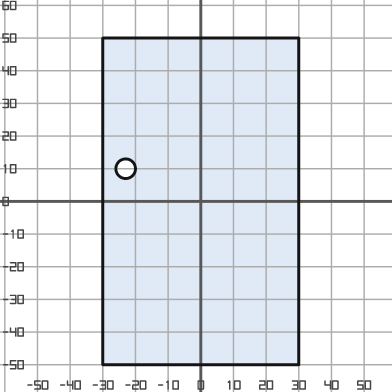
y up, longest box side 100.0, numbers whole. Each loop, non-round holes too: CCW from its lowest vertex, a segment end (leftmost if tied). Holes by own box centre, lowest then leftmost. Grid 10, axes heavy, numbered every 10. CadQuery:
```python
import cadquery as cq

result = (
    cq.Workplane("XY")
    .moveTo(-30.0, -50.0)
    .lineTo(30.0, -50.0)
    .lineTo(30.0, 50.0)
    .lineTo(-30.0, 50.0)
    .close()
    .moveTo(-23.0, 10.0)
    .circle(3.0)
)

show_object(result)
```